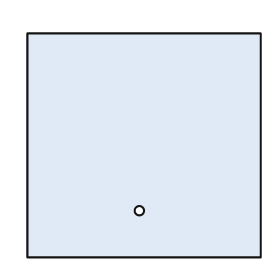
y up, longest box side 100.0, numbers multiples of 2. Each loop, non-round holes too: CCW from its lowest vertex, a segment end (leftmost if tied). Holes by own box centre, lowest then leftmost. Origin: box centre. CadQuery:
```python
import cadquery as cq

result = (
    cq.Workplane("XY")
    .moveTo(-50.0, -48.0)
    .lineTo(50.0, -48.0)
    .lineTo(50.0, 48.0)
    .lineTo(-50.0, 48.0)
    .close()
    .moveTo(-2.0, -28.0)
    .circle(2.0)
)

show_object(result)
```